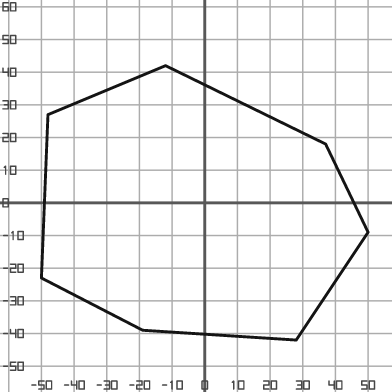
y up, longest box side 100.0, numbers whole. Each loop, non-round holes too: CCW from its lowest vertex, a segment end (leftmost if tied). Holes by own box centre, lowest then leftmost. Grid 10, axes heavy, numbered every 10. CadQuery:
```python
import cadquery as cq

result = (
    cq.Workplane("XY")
    .moveTo(28.0, -42.0)
    .lineTo(50.0, -9.0)
    .lineTo(37.0, 18.0)
    .lineTo(-12.0, 42.0)
    .lineTo(-48.0, 27.0)
    .lineTo(-50.0, -23.0)
    .lineTo(-19.0, -39.0)
    .close()
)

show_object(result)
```